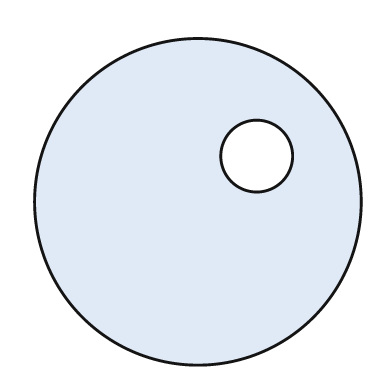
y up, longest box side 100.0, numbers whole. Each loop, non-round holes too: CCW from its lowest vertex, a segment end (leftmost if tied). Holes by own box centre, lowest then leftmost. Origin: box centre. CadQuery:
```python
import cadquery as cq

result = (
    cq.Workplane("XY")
    .moveTo(0.0, 0.0)
    .circle(50.0)
    .moveTo(18.0, 14.0)
    .circle(11.0)
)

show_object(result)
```